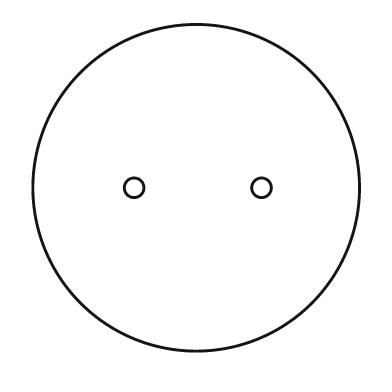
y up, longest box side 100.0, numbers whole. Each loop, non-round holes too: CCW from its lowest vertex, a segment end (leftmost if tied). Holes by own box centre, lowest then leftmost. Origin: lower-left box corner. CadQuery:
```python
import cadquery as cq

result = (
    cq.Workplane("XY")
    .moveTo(50.0, 50.0)
    .circle(50.0)
    .moveTo(31.0, 50.0)
    .circle(3.0)
    .moveTo(70.0, 50.0)
    .circle(3.0)
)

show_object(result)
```